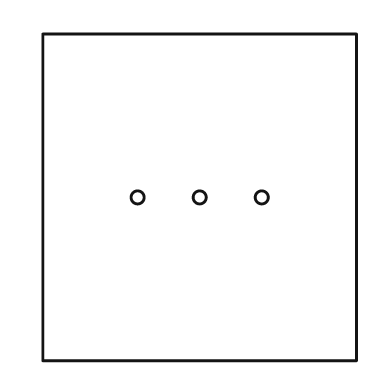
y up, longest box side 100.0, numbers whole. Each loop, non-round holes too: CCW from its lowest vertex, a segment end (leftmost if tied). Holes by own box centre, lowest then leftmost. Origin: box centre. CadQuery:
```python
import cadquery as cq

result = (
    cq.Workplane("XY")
    .moveTo(-48.0, -50.0)
    .lineTo(48.0, -50.0)
    .lineTo(48.0, 50.0)
    .lineTo(-48.0, 50.0)
    .close()
    .moveTo(-19.0, 0.0)
    .circle(2.0)
    .moveTo(0.0, 0.0)
    .circle(2.0)
    .moveTo(19.0, 0.0)
    .circle(2.0)
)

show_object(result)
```